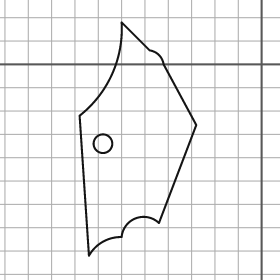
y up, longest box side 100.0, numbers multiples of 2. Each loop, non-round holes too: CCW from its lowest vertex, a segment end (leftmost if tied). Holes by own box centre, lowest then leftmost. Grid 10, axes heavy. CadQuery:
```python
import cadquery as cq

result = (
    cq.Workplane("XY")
    .moveTo(-74.0, -82.0)
    .threePointArc((-68.0, -76.0), (-60.0, -74.0))
    .threePointArc((-54.0, -66.0), (-44.0, -68.0))
    .lineTo(-28.0, -26.0)
    .lineTo(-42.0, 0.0)
    .threePointArc((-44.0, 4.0), (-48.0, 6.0))
    .lineTo(-60.0, 18.0)
    .threePointArc((-64.0, -4.0), (-78.0, -22.0))
    .close()
    .moveTo(-68.0, -34.0)
    .circle(4.0)
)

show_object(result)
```